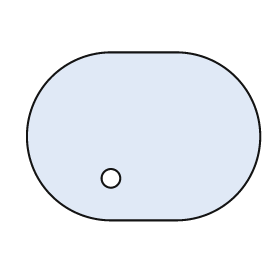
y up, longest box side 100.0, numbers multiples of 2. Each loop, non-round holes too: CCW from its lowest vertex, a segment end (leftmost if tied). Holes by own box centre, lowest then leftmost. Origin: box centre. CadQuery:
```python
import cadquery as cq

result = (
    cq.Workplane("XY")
    .moveTo(-14.0, -36.0)
    .lineTo(14.0, -36.0)
    .threePointArc((50.0, 0.0), (14.0, 36.0))
    .lineTo(-14.0, 36.0)
    .threePointArc((-50.0, 0.0), (-14.0, -36.0))
    .close()
    .moveTo(-14.0, -18.0)
    .circle(4.0)
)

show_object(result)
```